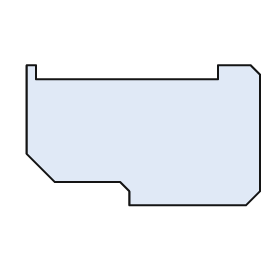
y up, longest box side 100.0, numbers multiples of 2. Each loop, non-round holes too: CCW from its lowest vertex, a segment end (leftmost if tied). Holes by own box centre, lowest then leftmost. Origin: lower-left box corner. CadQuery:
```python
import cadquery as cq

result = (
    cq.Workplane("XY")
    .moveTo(44.0, 0.0)
    .lineTo(94.0, 0.0)
    .lineTo(100.0, 6.0)
    .lineTo(100.0, 56.0)
    .lineTo(96.0, 60.0)
    .lineTo(82.0, 60.0)
    .lineTo(82.0, 54.0)
    .lineTo(4.0, 54.0)
    .lineTo(4.0, 60.0)
    .lineTo(0.0, 60.0)
    .lineTo(0.0, 22.0)
    .lineTo(12.0, 10.0)
    .lineTo(40.0, 10.0)
    .lineTo(44.0, 6.0)
    .close()
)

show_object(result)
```